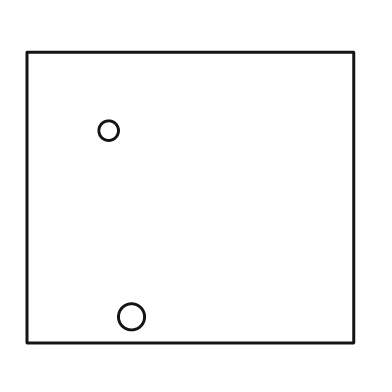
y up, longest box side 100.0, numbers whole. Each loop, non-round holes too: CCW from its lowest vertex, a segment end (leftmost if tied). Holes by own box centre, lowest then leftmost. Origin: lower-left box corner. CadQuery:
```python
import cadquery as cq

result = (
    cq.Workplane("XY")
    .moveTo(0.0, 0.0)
    .lineTo(100.0, 0.0)
    .lineTo(100.0, 89.0)
    .lineTo(0.0, 89.0)
    .close()
    .moveTo(32.0, 8.0)
    .circle(4.0)
    .moveTo(25.0, 65.0)
    .circle(3.0)
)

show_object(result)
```